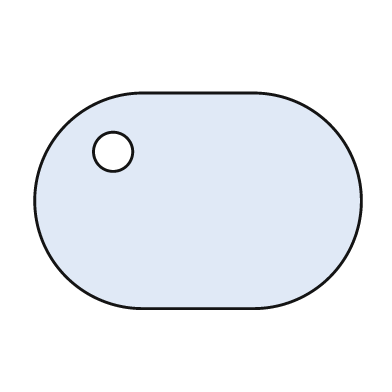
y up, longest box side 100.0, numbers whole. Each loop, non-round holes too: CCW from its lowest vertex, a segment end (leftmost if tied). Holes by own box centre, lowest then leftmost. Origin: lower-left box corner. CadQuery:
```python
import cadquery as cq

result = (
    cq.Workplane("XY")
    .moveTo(33.0, 0.0)
    .lineTo(67.0, 0.0)
    .threePointArc((100.0, 33.0), (67.0, 66.0))
    .lineTo(33.0, 66.0)
    .threePointArc((0.0, 33.0), (33.0, 0.0))
    .close()
    .moveTo(24.0, 48.0)
    .circle(6.0)
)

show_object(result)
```